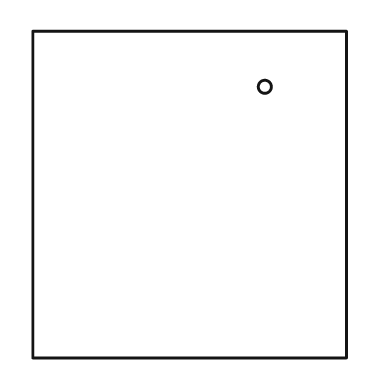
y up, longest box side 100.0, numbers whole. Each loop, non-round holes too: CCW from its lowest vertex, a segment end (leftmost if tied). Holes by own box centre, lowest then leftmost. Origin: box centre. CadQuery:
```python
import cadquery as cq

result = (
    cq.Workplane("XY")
    .moveTo(-48.0, -50.0)
    .lineTo(48.0, -50.0)
    .lineTo(48.0, 50.0)
    .lineTo(-48.0, 50.0)
    .close()
    .moveTo(23.0, 33.0)
    .circle(2.0)
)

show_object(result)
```